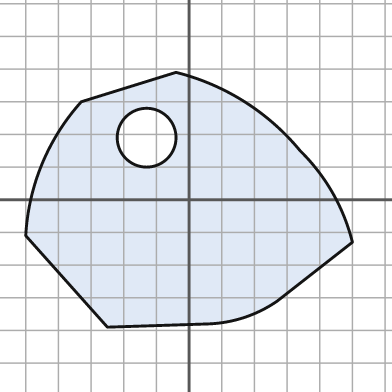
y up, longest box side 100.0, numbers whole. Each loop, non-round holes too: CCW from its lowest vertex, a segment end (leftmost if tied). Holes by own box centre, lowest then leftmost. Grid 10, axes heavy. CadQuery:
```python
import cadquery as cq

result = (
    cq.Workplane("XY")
    .moveTo(-25.0, -39.0)
    .lineTo(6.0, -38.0)
    .threePointArc((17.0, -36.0), (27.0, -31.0))
    .lineTo(50.0, -13.0)
    .threePointArc((44.0, 2.0), (34.0, 15.0))
    .threePointArc((17.0, 30.0), (-4.0, 39.0))
    .lineTo(-33.0, 30.0)
    .threePointArc((-45.0, 11.0), (-50.0, -11.0))
    .close()
    .moveTo(-13.0, 19.0)
    .circle(9.0)
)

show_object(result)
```